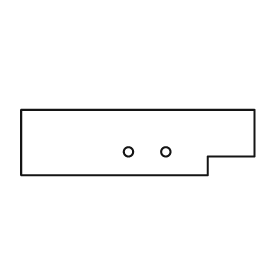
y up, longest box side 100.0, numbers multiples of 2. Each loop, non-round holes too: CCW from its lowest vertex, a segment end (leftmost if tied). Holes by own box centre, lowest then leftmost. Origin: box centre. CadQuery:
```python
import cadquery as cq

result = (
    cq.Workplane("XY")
    .moveTo(-50.0, -14.0)
    .lineTo(30.0, -14.0)
    .lineTo(30.0, -6.0)
    .lineTo(50.0, -6.0)
    .lineTo(50.0, 14.0)
    .lineTo(-50.0, 14.0)
    .close()
    .moveTo(-4.0, -4.0)
    .circle(2.0)
    .moveTo(12.0, -4.0)
    .circle(2.0)
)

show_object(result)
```